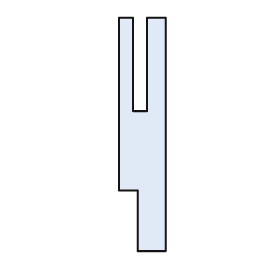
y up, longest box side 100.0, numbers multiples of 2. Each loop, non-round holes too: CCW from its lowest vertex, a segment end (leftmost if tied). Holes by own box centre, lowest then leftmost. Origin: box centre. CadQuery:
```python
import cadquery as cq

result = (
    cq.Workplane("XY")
    .moveTo(-2.0, -50.0)
    .lineTo(10.0, -50.0)
    .lineTo(10.0, 50.0)
    .lineTo(2.0, 50.0)
    .lineTo(2.0, 10.0)
    .lineTo(-4.0, 10.0)
    .lineTo(-4.0, 50.0)
    .lineTo(-10.0, 50.0)
    .lineTo(-10.0, -24.0)
    .lineTo(-2.0, -24.0)
    .close()
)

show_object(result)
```